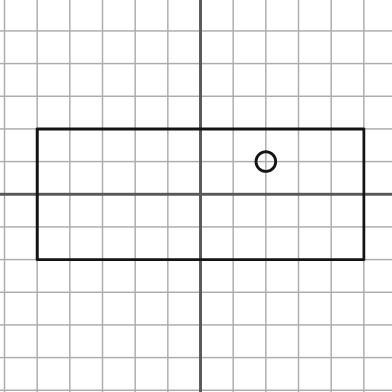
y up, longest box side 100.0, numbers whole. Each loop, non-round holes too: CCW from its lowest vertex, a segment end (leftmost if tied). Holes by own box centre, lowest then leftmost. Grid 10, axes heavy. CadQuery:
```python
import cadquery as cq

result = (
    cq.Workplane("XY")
    .moveTo(-50.0, -20.0)
    .lineTo(50.0, -20.0)
    .lineTo(50.0, 20.0)
    .lineTo(-50.0, 20.0)
    .close()
    .moveTo(20.0, 10.0)
    .circle(3.0)
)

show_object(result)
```